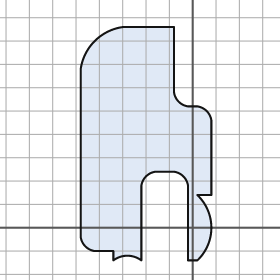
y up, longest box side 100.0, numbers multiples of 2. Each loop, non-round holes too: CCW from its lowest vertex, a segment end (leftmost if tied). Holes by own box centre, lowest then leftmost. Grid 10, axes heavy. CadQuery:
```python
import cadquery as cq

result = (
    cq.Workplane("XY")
    .moveTo(-34.0, -14.0)
    .threePointArc((-28.0, -12.0), (-22.0, -14.0))
    .lineTo(-22.0, 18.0)
    .threePointArc((-20.0, 22.0), (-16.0, 24.0))
    .lineTo(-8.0, 24.0)
    .threePointArc((-4.0, 22.0), (-2.0, 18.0))
    .lineTo(-2.0, -14.0)
    .lineTo(2.0, -14.0)
    .threePointArc((8.0, 0.0), (2.0, 14.0))
    .lineTo(8.0, 14.0)
    .lineTo(8.0, 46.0)
    .threePointArc((6.0, 50.0), (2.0, 52.0))
    .lineTo(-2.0, 52.0)
    .threePointArc((-6.0, 54.0), (-8.0, 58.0))
    .lineTo(-8.0, 86.0)
    .lineTo(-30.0, 86.0)
    .threePointArc((-42.0, 80.0), (-48.0, 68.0))
    .lineTo(-48.0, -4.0)
    .threePointArc((-46.0, -8.0), (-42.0, -10.0))
    .lineTo(-34.0, -10.0)
    .close()
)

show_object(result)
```